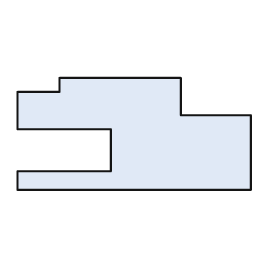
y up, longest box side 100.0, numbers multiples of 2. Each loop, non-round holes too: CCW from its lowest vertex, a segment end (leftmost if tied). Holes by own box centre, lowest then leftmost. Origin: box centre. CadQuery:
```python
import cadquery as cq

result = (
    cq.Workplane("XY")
    .moveTo(-50.0, -24.0)
    .lineTo(50.0, -24.0)
    .lineTo(50.0, 8.0)
    .lineTo(20.0, 8.0)
    .lineTo(20.0, 24.0)
    .lineTo(-32.0, 24.0)
    .lineTo(-32.0, 18.0)
    .lineTo(-50.0, 18.0)
    .lineTo(-50.0, 2.0)
    .lineTo(-10.0, 2.0)
    .lineTo(-10.0, -16.0)
    .lineTo(-50.0, -16.0)
    .close()
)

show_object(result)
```